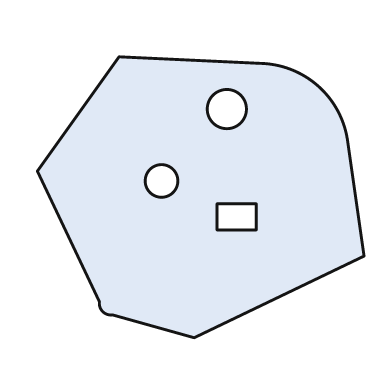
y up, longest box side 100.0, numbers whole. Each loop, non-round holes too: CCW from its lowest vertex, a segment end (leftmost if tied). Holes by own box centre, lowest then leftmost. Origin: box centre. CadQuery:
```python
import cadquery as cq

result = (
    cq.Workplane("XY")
    .moveTo(-2.0, -43.0)
    .lineTo(50.0, -18.0)
    .lineTo(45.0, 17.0)
    .threePointArc((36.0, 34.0), (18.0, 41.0))
    .lineTo(-25.0, 43.0)
    .lineTo(-50.0, 8.0)
    .lineTo(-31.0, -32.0)
    .threePointArc((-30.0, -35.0), (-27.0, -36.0))
    .close()
    .moveTo(5.0, -10.0)
    .lineTo(17.0, -10.0)
    .lineTo(17.0, -2.0)
    .lineTo(5.0, -2.0)
    .close()
    .moveTo(-12.0, 5.0)
    .circle(5.0)
    .moveTo(8.0, 27.0)
    .circle(6.0)
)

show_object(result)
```